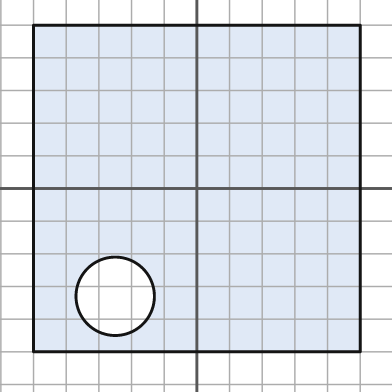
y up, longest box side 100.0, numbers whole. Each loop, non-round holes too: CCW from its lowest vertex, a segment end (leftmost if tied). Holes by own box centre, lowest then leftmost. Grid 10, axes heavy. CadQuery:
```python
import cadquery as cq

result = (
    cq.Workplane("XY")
    .moveTo(-50.0, -50.0)
    .lineTo(50.0, -50.0)
    .lineTo(50.0, 50.0)
    .lineTo(-50.0, 50.0)
    .close()
    .moveTo(-25.0, -33.0)
    .circle(12.0)
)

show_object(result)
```